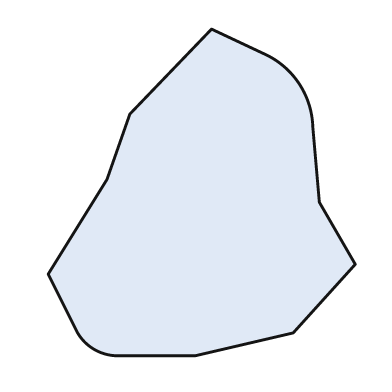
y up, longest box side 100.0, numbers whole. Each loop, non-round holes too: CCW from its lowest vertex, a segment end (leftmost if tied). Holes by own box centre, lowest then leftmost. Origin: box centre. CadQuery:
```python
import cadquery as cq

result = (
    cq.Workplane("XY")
    .moveTo(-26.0, -50.0)
    .lineTo(-2.0, -50.0)
    .lineTo(28.0, -43.0)
    .lineTo(47.0, -22.0)
    .lineTo(36.0, -3.0)
    .lineTo(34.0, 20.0)
    .threePointArc((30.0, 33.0), (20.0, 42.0))
    .lineTo(3.0, 50.0)
    .lineTo(-22.0, 24.0)
    .lineTo(-29.0, 4.0)
    .lineTo(-47.0, -25.0)
    .lineTo(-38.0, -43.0)
    .threePointArc((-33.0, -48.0), (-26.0, -50.0))
    .close()
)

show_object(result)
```